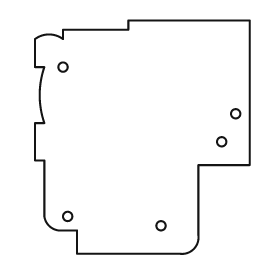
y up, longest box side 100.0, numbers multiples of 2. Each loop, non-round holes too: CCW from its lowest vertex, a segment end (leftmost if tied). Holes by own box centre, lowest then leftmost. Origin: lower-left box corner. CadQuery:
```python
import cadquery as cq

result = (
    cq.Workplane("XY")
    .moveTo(18.0, 0.0)
    .lineTo(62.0, 0.0)
    .threePointArc((68.0, 2.0), (70.0, 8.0))
    .lineTo(70.0, 38.0)
    .lineTo(92.0, 38.0)
    .lineTo(92.0, 100.0)
    .lineTo(40.0, 100.0)
    .lineTo(40.0, 96.0)
    .lineTo(12.0, 96.0)
    .lineTo(12.0, 92.0)
    .threePointArc((6.0, 94.0), (0.0, 92.0))
    .lineTo(0.0, 80.0)
    .lineTo(4.0, 80.0)
    .threePointArc((2.0, 68.0), (4.0, 56.0))
    .lineTo(0.0, 56.0)
    .lineTo(0.0, 40.0)
    .lineTo(4.0, 40.0)
    .lineTo(4.0, 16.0)
    .threePointArc((6.0, 12.0), (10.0, 10.0))
    .lineTo(18.0, 10.0)
    .close()
    .moveTo(54.0, 12.0)
    .circle(2.0)
    .moveTo(14.0, 16.0)
    .circle(2.0)
    .moveTo(80.0, 48.0)
    .circle(2.0)
    .moveTo(86.0, 60.0)
    .circle(2.0)
    .moveTo(12.0, 80.0)
    .circle(2.0)
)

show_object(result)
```